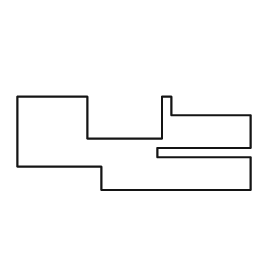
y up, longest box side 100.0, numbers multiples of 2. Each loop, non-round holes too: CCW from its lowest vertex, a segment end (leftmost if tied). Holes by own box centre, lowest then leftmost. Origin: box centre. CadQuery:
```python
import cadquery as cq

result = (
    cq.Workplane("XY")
    .moveTo(-14.0, -20.0)
    .lineTo(50.0, -20.0)
    .lineTo(50.0, -6.0)
    .lineTo(10.0, -6.0)
    .lineTo(10.0, -2.0)
    .lineTo(50.0, -2.0)
    .lineTo(50.0, 12.0)
    .lineTo(16.0, 12.0)
    .lineTo(16.0, 20.0)
    .lineTo(12.0, 20.0)
    .lineTo(12.0, 2.0)
    .lineTo(-20.0, 2.0)
    .lineTo(-20.0, 20.0)
    .lineTo(-50.0, 20.0)
    .lineTo(-50.0, -10.0)
    .lineTo(-14.0, -10.0)
    .close()
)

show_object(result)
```